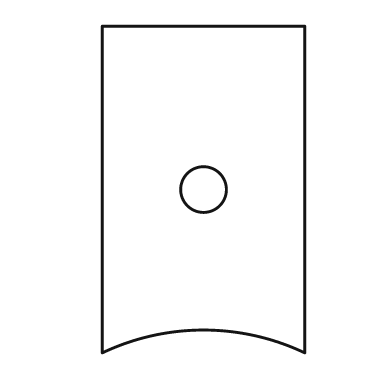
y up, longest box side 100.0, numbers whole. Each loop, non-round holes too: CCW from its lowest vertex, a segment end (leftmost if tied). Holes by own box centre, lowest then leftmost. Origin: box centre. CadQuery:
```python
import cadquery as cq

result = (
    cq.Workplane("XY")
    .moveTo(-31.0, -50.0)
    .threePointArc((0.0, -43.0), (31.0, -50.0))
    .lineTo(31.0, 50.0)
    .lineTo(-31.0, 50.0)
    .close()
    .moveTo(0.0, 0.0)
    .circle(7.0)
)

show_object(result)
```